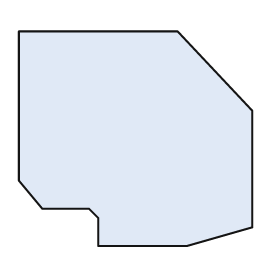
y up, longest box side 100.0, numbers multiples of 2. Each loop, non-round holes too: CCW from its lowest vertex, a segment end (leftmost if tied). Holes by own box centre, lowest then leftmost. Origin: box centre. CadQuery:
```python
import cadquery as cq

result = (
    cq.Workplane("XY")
    .moveTo(-16.0, -46.0)
    .lineTo(22.0, -46.0)
    .lineTo(50.0, -38.0)
    .lineTo(50.0, 12.0)
    .lineTo(18.0, 46.0)
    .lineTo(-50.0, 46.0)
    .lineTo(-50.0, -18.0)
    .lineTo(-40.0, -30.0)
    .lineTo(-20.0, -30.0)
    .lineTo(-16.0, -34.0)
    .close()
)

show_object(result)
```